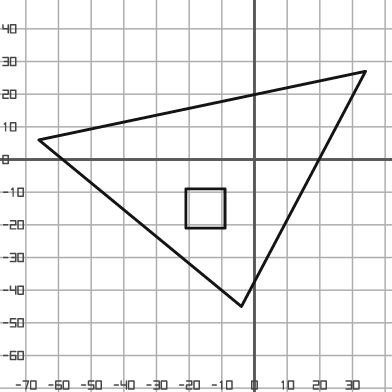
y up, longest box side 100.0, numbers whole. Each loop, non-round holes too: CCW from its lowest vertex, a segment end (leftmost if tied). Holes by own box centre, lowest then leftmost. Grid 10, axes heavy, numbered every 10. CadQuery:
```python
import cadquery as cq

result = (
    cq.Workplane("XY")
    .moveTo(-4.0, -45.0)
    .lineTo(34.0, 27.0)
    .lineTo(-66.0, 6.0)
    .close()
    .moveTo(-21.0, -21.0)
    .lineTo(-9.0, -21.0)
    .lineTo(-9.0, -9.0)
    .lineTo(-21.0, -9.0)
    .close()
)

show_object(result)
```